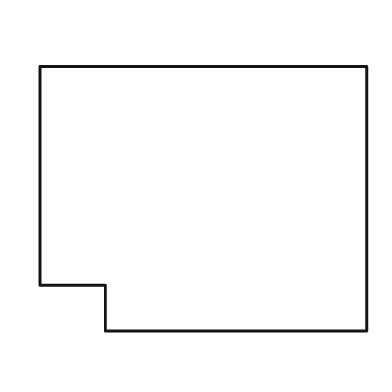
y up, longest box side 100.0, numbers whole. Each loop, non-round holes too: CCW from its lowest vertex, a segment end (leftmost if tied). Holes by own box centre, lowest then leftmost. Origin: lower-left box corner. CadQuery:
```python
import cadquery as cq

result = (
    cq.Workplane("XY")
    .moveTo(20.0, 0.0)
    .lineTo(100.0, 0.0)
    .lineTo(100.0, 81.0)
    .lineTo(0.0, 81.0)
    .lineTo(0.0, 14.0)
    .lineTo(20.0, 14.0)
    .close()
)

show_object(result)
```